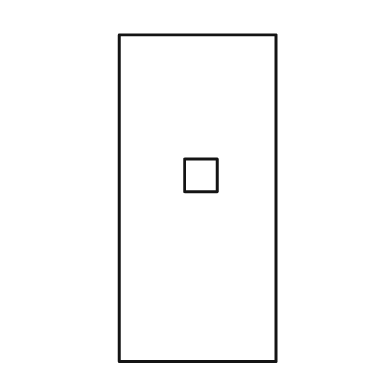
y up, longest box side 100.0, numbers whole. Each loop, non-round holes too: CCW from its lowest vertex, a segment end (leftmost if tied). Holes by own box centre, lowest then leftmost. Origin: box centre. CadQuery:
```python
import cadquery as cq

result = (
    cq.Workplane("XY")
    .moveTo(-24.0, -50.0)
    .lineTo(24.0, -50.0)
    .lineTo(24.0, 50.0)
    .lineTo(-24.0, 50.0)
    .close()
    .moveTo(-4.0, 2.0)
    .lineTo(6.0, 2.0)
    .lineTo(6.0, 12.0)
    .lineTo(-4.0, 12.0)
    .close()
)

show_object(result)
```